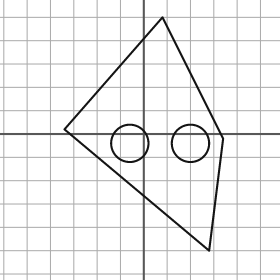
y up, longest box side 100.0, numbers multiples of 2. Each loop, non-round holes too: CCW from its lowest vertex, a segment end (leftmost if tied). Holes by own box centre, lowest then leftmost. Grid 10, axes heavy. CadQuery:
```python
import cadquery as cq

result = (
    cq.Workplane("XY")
    .moveTo(28.0, -50.0)
    .lineTo(34.0, -2.0)
    .lineTo(8.0, 50.0)
    .lineTo(-34.0, 2.0)
    .close()
    .moveTo(-6.0, -4.0)
    .circle(8.0)
    .moveTo(20.0, -4.0)
    .circle(8.0)
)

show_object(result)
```